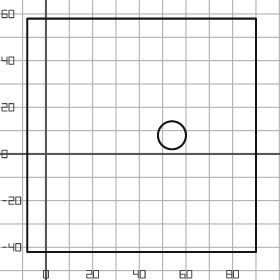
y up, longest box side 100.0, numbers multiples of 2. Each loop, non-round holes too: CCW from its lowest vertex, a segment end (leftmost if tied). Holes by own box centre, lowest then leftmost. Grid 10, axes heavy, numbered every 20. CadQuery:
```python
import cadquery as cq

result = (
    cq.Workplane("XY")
    .moveTo(-8.0, -42.0)
    .lineTo(90.0, -42.0)
    .lineTo(90.0, 58.0)
    .lineTo(-8.0, 58.0)
    .close()
    .moveTo(54.0, 8.0)
    .circle(6.0)
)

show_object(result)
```